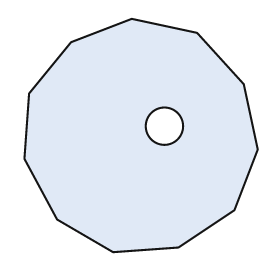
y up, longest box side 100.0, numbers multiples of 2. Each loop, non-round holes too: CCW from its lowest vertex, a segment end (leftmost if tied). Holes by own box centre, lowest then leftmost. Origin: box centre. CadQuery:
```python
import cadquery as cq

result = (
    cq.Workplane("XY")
    .moveTo(-12.0, -50.0)
    .lineTo(16.0, -48.0)
    .lineTo(40.0, -32.0)
    .lineTo(50.0, -6.0)
    .lineTo(44.0, 22.0)
    .lineTo(24.0, 44.0)
    .lineTo(-4.0, 50.0)
    .lineTo(-30.0, 40.0)
    .lineTo(-48.0, 18.0)
    .lineTo(-50.0, -10.0)
    .lineTo(-36.0, -36.0)
    .close()
    .moveTo(10.0, 4.0)
    .circle(8.0)
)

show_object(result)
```